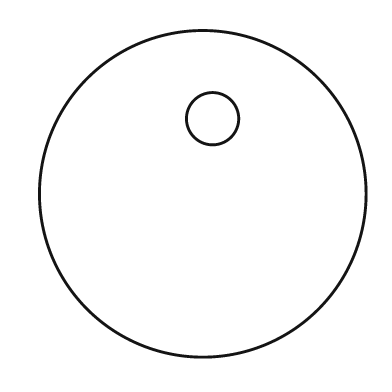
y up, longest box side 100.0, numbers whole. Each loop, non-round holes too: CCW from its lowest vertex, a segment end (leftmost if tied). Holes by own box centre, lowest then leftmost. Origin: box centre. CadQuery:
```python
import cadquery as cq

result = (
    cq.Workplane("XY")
    .moveTo(0.0, 0.0)
    .circle(50.0)
    .moveTo(3.0, 23.0)
    .circle(8.0)
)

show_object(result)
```